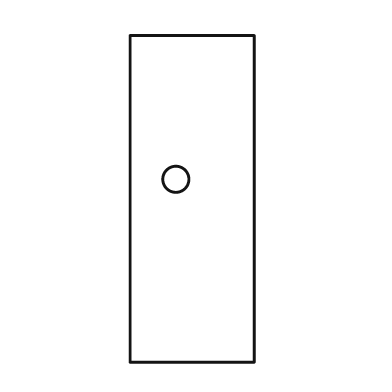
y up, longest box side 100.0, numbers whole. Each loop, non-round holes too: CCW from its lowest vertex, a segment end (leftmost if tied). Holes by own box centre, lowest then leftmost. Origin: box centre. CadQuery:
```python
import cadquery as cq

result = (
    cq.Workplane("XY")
    .moveTo(-19.0, -50.0)
    .lineTo(19.0, -50.0)
    .lineTo(19.0, 50.0)
    .lineTo(-19.0, 50.0)
    .close()
    .moveTo(-5.0, 6.0)
    .circle(4.0)
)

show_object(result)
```